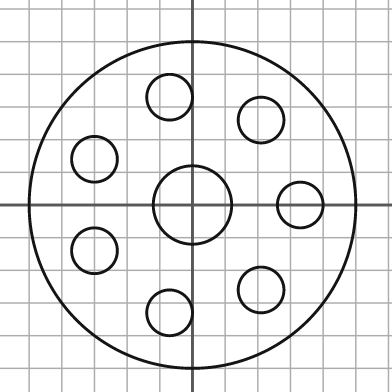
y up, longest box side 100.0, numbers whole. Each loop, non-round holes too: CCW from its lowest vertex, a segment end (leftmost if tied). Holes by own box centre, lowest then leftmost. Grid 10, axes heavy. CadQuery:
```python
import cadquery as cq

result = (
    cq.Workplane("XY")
    .moveTo(0.0, 0.0)
    .circle(50.0)
    .moveTo(-7.0, -33.0)
    .circle(7.0)
    .moveTo(21.0, -26.0)
    .circle(7.0)
    .moveTo(-30.0, -14.0)
    .circle(7.0)
    .moveTo(0.0, 0.0)
    .circle(12.0)
    .moveTo(33.0, 0.0)
    .circle(7.0)
    .moveTo(-30.0, 14.0)
    .circle(7.0)
    .moveTo(21.0, 26.0)
    .circle(7.0)
    .moveTo(-7.0, 33.0)
    .circle(7.0)
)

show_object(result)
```